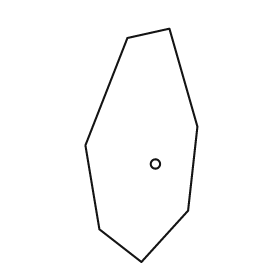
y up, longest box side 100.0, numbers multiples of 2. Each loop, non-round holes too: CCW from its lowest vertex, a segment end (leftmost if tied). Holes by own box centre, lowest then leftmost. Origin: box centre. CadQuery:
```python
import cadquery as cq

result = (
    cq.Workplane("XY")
    .moveTo(0.0, -50.0)
    .lineTo(20.0, -28.0)
    .lineTo(24.0, 8.0)
    .lineTo(12.0, 50.0)
    .lineTo(-6.0, 46.0)
    .lineTo(-24.0, 0.0)
    .lineTo(-18.0, -36.0)
    .close()
    .moveTo(6.0, -8.0)
    .circle(2.0)
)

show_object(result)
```